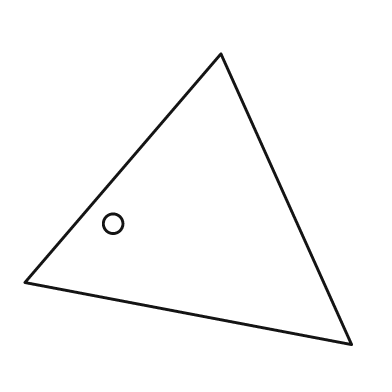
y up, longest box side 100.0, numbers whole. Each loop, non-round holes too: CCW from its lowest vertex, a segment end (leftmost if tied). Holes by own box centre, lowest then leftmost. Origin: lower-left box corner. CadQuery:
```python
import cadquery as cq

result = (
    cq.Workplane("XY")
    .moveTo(100.0, 0.0)
    .lineTo(60.0, 89.0)
    .lineTo(0.0, 19.0)
    .close()
    .moveTo(27.0, 37.0)
    .circle(3.0)
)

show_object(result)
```